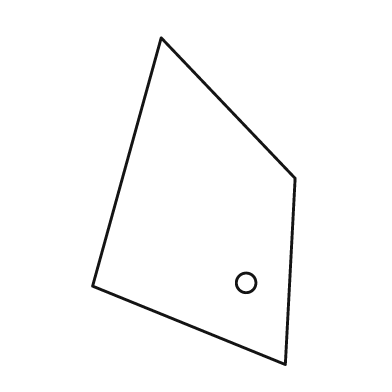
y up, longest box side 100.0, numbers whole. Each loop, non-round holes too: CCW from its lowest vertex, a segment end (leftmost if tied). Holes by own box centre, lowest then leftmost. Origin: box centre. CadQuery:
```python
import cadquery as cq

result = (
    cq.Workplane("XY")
    .moveTo(28.0, -50.0)
    .lineTo(31.0, 7.0)
    .lineTo(-10.0, 50.0)
    .lineTo(-31.0, -26.0)
    .close()
    .moveTo(16.0, -25.0)
    .circle(3.0)
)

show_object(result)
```